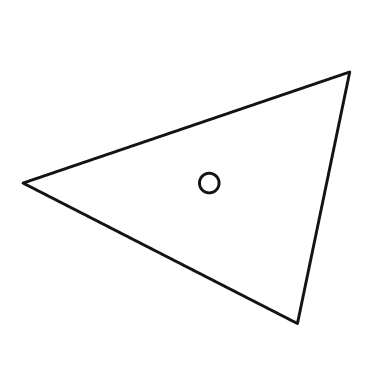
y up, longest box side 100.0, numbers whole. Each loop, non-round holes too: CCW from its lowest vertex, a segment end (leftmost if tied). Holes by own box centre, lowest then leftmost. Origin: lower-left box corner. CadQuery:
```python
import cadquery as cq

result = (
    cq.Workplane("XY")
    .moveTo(84.0, 0.0)
    .lineTo(100.0, 77.0)
    .lineTo(0.0, 43.0)
    .close()
    .moveTo(57.0, 43.0)
    .circle(3.0)
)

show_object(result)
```